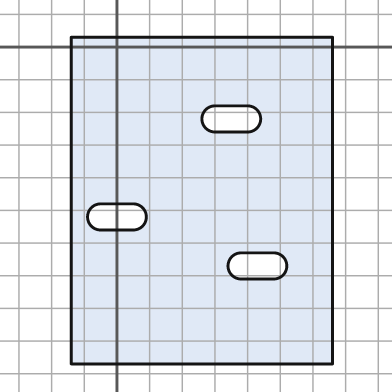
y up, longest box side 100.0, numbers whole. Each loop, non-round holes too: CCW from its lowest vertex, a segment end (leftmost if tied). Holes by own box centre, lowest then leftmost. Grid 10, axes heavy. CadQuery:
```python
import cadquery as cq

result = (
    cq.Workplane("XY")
    .moveTo(-14.0, -97.0)
    .lineTo(66.0, -97.0)
    .lineTo(66.0, 3.0)
    .lineTo(-14.0, 3.0)
    .close()
    .moveTo(38.0, -71.0)
    .lineTo(48.0, -71.0)
    .threePointArc((52.0, -67.0), (48.0, -63.0))
    .lineTo(38.0, -63.0)
    .threePointArc((34.0, -67.0), (38.0, -71.0))
    .close()
    .moveTo(-5.0, -56.0)
    .lineTo(5.0, -56.0)
    .threePointArc((9.0, -52.0), (5.0, -48.0))
    .lineTo(-5.0, -48.0)
    .threePointArc((-9.0, -52.0), (-5.0, -56.0))
    .close()
    .moveTo(30.0, -26.0)
    .lineTo(40.0, -26.0)
    .threePointArc((44.0, -22.0), (40.0, -18.0))
    .lineTo(30.0, -18.0)
    .threePointArc((26.0, -22.0), (30.0, -26.0))
    .close()
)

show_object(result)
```